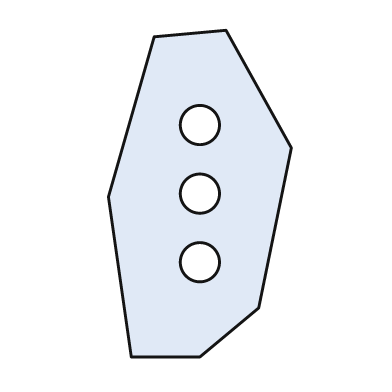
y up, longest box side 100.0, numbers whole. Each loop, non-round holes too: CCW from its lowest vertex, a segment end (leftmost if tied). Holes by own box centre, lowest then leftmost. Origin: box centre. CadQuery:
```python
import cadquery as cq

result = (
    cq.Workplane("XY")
    .moveTo(-21.0, -50.0)
    .lineTo(0.0, -50.0)
    .lineTo(18.0, -35.0)
    .lineTo(28.0, 14.0)
    .lineTo(8.0, 50.0)
    .lineTo(-14.0, 48.0)
    .lineTo(-28.0, -1.0)
    .close()
    .moveTo(0.0, -21.0)
    .circle(6.0)
    .moveTo(0.0, 0.0)
    .circle(6.0)
    .moveTo(0.0, 21.0)
    .circle(6.0)
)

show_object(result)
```